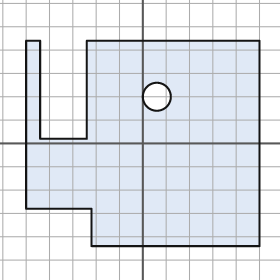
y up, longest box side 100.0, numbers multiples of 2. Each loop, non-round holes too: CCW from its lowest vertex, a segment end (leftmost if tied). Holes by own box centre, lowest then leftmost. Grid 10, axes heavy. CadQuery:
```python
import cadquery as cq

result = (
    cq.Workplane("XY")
    .moveTo(-22.0, -44.0)
    .lineTo(50.0, -44.0)
    .lineTo(50.0, 44.0)
    .lineTo(-24.0, 44.0)
    .lineTo(-24.0, 2.0)
    .lineTo(-44.0, 2.0)
    .lineTo(-44.0, 44.0)
    .lineTo(-50.0, 44.0)
    .lineTo(-50.0, -28.0)
    .lineTo(-22.0, -28.0)
    .close()
    .moveTo(6.0, 20.0)
    .circle(6.0)
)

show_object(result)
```